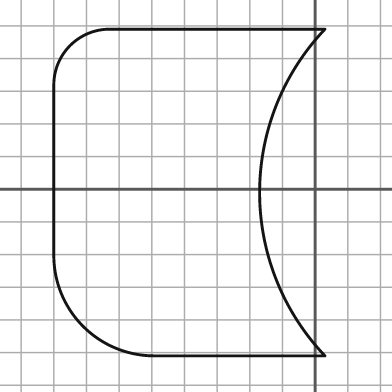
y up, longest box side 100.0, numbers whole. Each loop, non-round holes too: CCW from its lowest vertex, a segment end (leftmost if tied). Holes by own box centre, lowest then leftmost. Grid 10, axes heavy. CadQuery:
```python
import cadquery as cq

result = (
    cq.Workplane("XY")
    .moveTo(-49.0, -51.0)
    .lineTo(3.0, -51.0)
    .threePointArc((-17.0, -1.0), (3.0, 49.0))
    .lineTo(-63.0, 49.0)
    .threePointArc((-75.0, 44.0), (-80.0, 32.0))
    .lineTo(-80.0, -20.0)
    .threePointArc((-71.0, -42.0), (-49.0, -51.0))
    .close()
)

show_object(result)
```